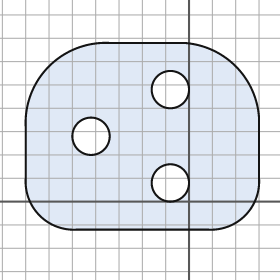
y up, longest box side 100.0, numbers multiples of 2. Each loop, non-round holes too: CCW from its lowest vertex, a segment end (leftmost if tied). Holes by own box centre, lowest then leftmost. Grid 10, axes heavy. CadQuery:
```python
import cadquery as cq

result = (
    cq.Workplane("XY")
    .moveTo(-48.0, -12.0)
    .lineTo(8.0, -12.0)
    .threePointArc((24.0, -6.0), (30.0, 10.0))
    .lineTo(30.0, 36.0)
    .threePointArc((20.0, 58.0), (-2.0, 68.0))
    .lineTo(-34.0, 68.0)
    .threePointArc((-60.0, 58.0), (-70.0, 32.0))
    .lineTo(-70.0, 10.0)
    .threePointArc((-64.0, -6.0), (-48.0, -12.0))
    .close()
    .moveTo(-8.0, 8.0)
    .circle(8.0)
    .moveTo(-42.0, 28.0)
    .circle(8.0)
    .moveTo(-8.0, 48.0)
    .circle(8.0)
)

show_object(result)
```